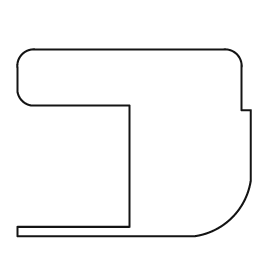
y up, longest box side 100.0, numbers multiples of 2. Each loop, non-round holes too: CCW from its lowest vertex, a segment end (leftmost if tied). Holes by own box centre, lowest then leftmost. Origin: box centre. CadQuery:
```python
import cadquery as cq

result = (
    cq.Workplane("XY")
    .moveTo(-50.0, -40.0)
    .lineTo(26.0, -40.0)
    .threePointArc((42.0, -32.0), (50.0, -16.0))
    .lineTo(50.0, 14.0)
    .lineTo(46.0, 14.0)
    .lineTo(46.0, 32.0)
    .threePointArc((44.0, 38.0), (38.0, 40.0))
    .lineTo(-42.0, 40.0)
    .threePointArc((-48.0, 38.0), (-50.0, 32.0))
    .lineTo(-50.0, 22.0)
    .threePointArc((-48.0, 18.0), (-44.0, 16.0))
    .lineTo(-2.0, 16.0)
    .lineTo(-2.0, -36.0)
    .lineTo(-50.0, -36.0)
    .close()
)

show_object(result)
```